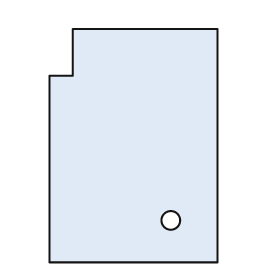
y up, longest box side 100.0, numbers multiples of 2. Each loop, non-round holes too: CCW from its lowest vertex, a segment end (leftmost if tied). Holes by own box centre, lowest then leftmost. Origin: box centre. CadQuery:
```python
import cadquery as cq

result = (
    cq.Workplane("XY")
    .moveTo(-36.0, -50.0)
    .lineTo(36.0, -50.0)
    .lineTo(36.0, 50.0)
    .lineTo(-26.0, 50.0)
    .lineTo(-26.0, 30.0)
    .lineTo(-36.0, 30.0)
    .close()
    .moveTo(16.0, -32.0)
    .circle(4.0)
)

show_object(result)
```